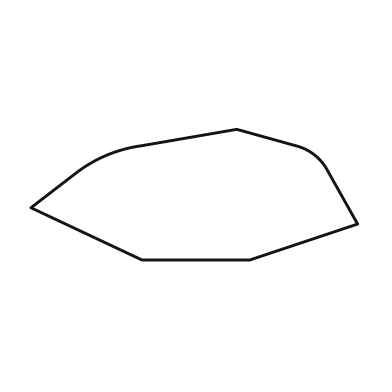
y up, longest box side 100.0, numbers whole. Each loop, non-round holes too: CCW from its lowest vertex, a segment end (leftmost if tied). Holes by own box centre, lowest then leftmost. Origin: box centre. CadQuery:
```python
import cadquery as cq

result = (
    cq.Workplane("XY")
    .moveTo(-16.0, -20.0)
    .lineTo(17.0, -20.0)
    .lineTo(50.0, -9.0)
    .lineTo(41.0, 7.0)
    .threePointArc((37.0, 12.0), (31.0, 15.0))
    .lineTo(13.0, 20.0)
    .lineTo(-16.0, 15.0)
    .threePointArc((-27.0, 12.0), (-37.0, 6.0))
    .lineTo(-50.0, -4.0)
    .close()
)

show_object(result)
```